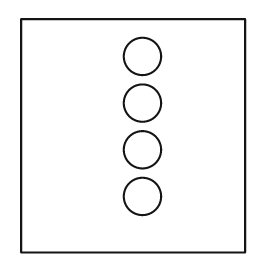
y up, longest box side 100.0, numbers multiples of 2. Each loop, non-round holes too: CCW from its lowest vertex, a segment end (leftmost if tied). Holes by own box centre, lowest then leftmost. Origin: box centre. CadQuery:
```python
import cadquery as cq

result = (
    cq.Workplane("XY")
    .moveTo(-48.0, -50.0)
    .lineTo(48.0, -50.0)
    .lineTo(48.0, 50.0)
    .lineTo(-48.0, 50.0)
    .close()
    .moveTo(4.0, -26.0)
    .circle(8.0)
    .moveTo(4.0, -6.0)
    .circle(8.0)
    .moveTo(4.0, 14.0)
    .circle(8.0)
    .moveTo(4.0, 34.0)
    .circle(8.0)
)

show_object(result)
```